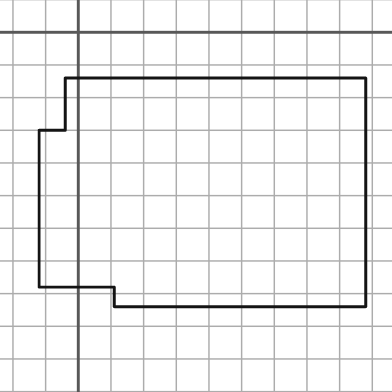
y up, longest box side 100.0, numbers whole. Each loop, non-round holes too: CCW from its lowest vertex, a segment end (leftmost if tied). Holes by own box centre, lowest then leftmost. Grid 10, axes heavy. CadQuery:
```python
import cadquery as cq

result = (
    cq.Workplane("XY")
    .moveTo(11.0, -84.0)
    .lineTo(88.0, -84.0)
    .lineTo(88.0, -14.0)
    .lineTo(-4.0, -14.0)
    .lineTo(-4.0, -30.0)
    .lineTo(-12.0, -30.0)
    .lineTo(-12.0, -78.0)
    .lineTo(11.0, -78.0)
    .close()
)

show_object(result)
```